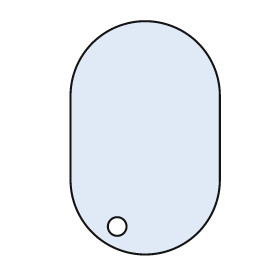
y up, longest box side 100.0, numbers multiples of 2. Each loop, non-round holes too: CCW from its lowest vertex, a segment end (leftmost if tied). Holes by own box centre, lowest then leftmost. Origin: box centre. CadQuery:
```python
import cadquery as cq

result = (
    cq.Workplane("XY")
    .moveTo(-32.0, -18.0)
    .threePointArc((0.0, -50.0), (32.0, -18.0))
    .lineTo(32.0, 18.0)
    .threePointArc((0.0, 50.0), (-32.0, 18.0))
    .close()
    .moveTo(-12.0, -38.0)
    .circle(4.0)
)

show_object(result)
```